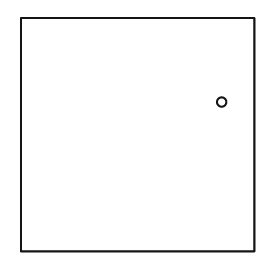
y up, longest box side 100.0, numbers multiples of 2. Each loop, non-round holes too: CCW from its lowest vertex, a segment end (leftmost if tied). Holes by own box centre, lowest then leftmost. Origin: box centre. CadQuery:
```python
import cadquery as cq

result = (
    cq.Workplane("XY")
    .moveTo(-50.0, -50.0)
    .lineTo(50.0, -50.0)
    .lineTo(50.0, 50.0)
    .lineTo(-50.0, 50.0)
    .close()
    .moveTo(36.0, 14.0)
    .circle(2.0)
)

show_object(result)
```